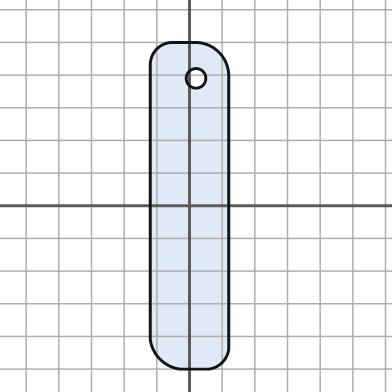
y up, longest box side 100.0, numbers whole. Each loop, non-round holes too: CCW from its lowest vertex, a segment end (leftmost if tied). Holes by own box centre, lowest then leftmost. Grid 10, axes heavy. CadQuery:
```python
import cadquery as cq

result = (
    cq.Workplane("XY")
    .moveTo(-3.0, -50.0)
    .lineTo(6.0, -50.0)
    .threePointArc((10.0, -48.0), (12.0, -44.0))
    .lineTo(12.0, 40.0)
    .threePointArc((9.0, 47.0), (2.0, 50.0))
    .lineTo(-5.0, 50.0)
    .threePointArc((-10.0, 48.0), (-12.0, 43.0))
    .lineTo(-12.0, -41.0)
    .threePointArc((-9.0, -47.0), (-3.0, -50.0))
    .close()
    .moveTo(2.0, 39.0)
    .circle(3.0)
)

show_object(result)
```